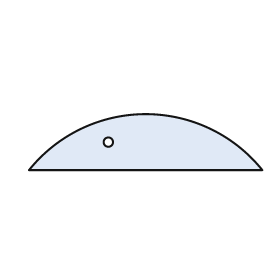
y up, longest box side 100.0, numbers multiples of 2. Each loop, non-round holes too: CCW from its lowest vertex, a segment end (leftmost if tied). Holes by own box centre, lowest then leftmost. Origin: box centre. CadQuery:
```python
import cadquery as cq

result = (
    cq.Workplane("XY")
    .moveTo(-50.0, -12.0)
    .lineTo(50.0, -12.0)
    .threePointArc((0.0, 12.0), (-50.0, -12.0))
    .close()
    .moveTo(-16.0, 0.0)
    .circle(2.0)
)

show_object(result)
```